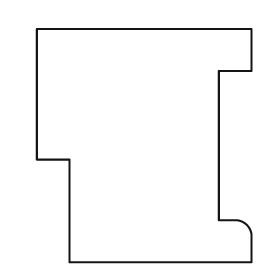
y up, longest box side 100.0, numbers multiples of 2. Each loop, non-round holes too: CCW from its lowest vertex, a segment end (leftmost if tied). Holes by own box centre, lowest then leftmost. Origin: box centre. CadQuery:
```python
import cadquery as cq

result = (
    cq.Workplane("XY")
    .moveTo(-32.0, -50.0)
    .lineTo(46.0, -50.0)
    .lineTo(46.0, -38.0)
    .threePointArc((44.0, -34.0), (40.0, -32.0))
    .lineTo(32.0, -32.0)
    .lineTo(32.0, 32.0)
    .lineTo(46.0, 32.0)
    .lineTo(46.0, 50.0)
    .lineTo(-46.0, 50.0)
    .lineTo(-46.0, -6.0)
    .lineTo(-32.0, -6.0)
    .close()
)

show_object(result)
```